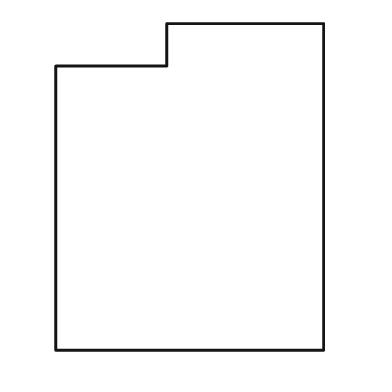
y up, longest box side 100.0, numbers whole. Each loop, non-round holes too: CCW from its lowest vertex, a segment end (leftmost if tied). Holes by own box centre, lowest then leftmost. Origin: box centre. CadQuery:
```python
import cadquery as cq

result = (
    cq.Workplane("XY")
    .moveTo(-41.0, -50.0)
    .lineTo(41.0, -50.0)
    .lineTo(41.0, 50.0)
    .lineTo(-7.0, 50.0)
    .lineTo(-7.0, 37.0)
    .lineTo(-41.0, 37.0)
    .close()
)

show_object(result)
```